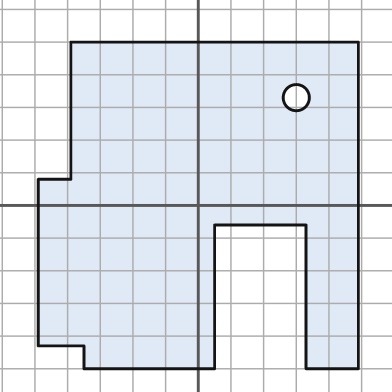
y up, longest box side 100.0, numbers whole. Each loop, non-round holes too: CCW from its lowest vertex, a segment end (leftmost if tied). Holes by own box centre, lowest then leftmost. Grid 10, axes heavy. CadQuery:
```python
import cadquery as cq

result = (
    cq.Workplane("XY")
    .moveTo(-35.0, -50.0)
    .lineTo(5.0, -50.0)
    .lineTo(5.0, -6.0)
    .lineTo(33.0, -6.0)
    .lineTo(33.0, -50.0)
    .lineTo(49.0, -50.0)
    .lineTo(49.0, 50.0)
    .lineTo(-39.0, 50.0)
    .lineTo(-39.0, 8.0)
    .lineTo(-49.0, 8.0)
    .lineTo(-49.0, -43.0)
    .lineTo(-35.0, -43.0)
    .close()
    .moveTo(30.0, 33.0)
    .circle(4.0)
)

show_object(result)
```